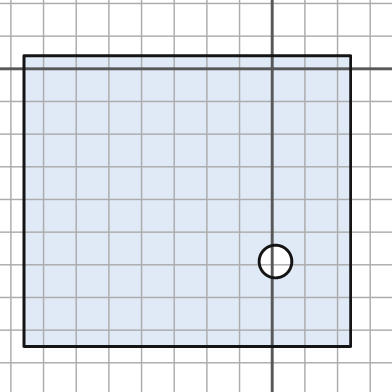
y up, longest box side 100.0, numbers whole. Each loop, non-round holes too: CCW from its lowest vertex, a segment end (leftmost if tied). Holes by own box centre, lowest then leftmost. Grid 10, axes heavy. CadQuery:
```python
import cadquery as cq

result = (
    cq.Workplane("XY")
    .moveTo(-76.0, -85.0)
    .lineTo(24.0, -85.0)
    .lineTo(24.0, 4.0)
    .lineTo(-76.0, 4.0)
    .close()
    .moveTo(1.0, -59.0)
    .circle(5.0)
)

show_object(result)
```